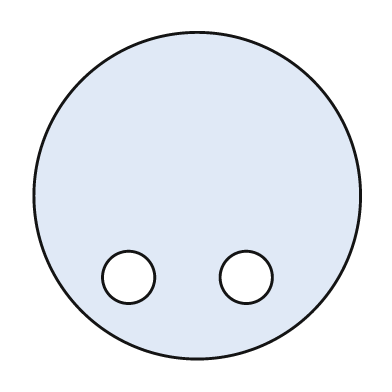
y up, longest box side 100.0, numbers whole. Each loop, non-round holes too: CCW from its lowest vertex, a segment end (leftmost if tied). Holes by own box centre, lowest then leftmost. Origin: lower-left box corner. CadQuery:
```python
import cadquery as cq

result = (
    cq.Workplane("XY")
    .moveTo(50.0, 50.0)
    .circle(50.0)
    .moveTo(29.0, 25.0)
    .circle(8.0)
    .moveTo(65.0, 25.0)
    .circle(8.0)
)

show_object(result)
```